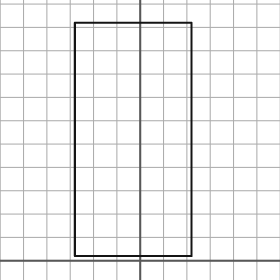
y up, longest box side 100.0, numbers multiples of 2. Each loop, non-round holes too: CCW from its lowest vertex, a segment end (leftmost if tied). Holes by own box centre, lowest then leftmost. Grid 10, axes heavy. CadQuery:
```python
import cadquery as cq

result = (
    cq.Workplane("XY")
    .moveTo(-28.0, 2.0)
    .lineTo(22.0, 2.0)
    .lineTo(22.0, 102.0)
    .lineTo(-28.0, 102.0)
    .close()
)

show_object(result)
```